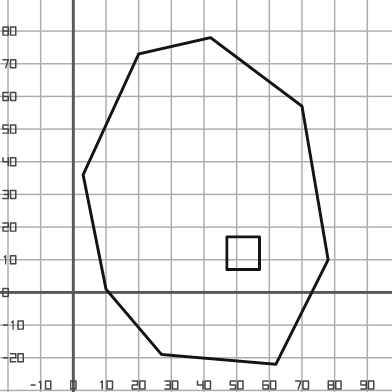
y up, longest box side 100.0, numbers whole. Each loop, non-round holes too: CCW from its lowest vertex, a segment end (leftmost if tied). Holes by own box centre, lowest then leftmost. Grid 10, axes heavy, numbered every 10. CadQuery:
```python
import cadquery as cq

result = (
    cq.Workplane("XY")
    .moveTo(62.0, -22.0)
    .lineTo(78.0, 10.0)
    .lineTo(70.0, 57.0)
    .lineTo(42.0, 78.0)
    .lineTo(20.0, 73.0)
    .lineTo(3.0, 36.0)
    .lineTo(10.0, 1.0)
    .lineTo(27.0, -19.0)
    .close()
    .moveTo(47.0, 7.0)
    .lineTo(57.0, 7.0)
    .lineTo(57.0, 17.0)
    .lineTo(47.0, 17.0)
    .close()
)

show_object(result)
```